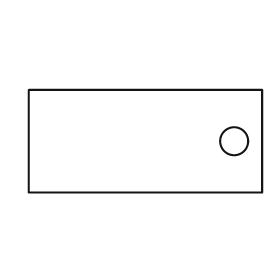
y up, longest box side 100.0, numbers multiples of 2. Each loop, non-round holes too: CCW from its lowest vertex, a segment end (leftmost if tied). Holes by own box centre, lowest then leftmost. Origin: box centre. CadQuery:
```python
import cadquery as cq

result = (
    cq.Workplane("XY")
    .moveTo(-50.0, -22.0)
    .lineTo(50.0, -22.0)
    .lineTo(50.0, 22.0)
    .lineTo(-50.0, 22.0)
    .close()
    .moveTo(38.0, 0.0)
    .circle(6.0)
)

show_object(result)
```